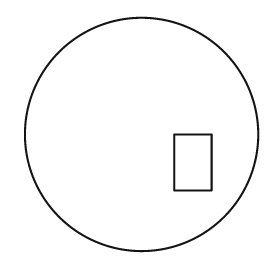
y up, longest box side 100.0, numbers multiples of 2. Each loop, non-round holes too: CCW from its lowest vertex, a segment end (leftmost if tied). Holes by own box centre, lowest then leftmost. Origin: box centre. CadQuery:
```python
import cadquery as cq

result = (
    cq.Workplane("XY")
    .moveTo(0.0, 0.0)
    .circle(50.0)
    .moveTo(14.0, -24.0)
    .lineTo(30.0, -24.0)
    .lineTo(30.0, 0.0)
    .lineTo(14.0, 0.0)
    .close()
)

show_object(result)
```